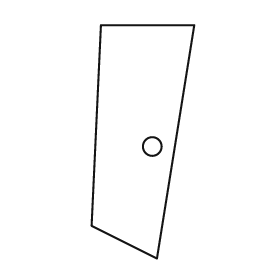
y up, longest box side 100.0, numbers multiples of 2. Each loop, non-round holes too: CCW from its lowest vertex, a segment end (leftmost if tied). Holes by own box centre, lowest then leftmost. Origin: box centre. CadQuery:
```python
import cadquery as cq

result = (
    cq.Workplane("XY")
    .moveTo(6.0, -50.0)
    .lineTo(22.0, 50.0)
    .lineTo(-18.0, 50.0)
    .lineTo(-22.0, -36.0)
    .close()
    .moveTo(4.0, -2.0)
    .circle(4.0)
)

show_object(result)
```